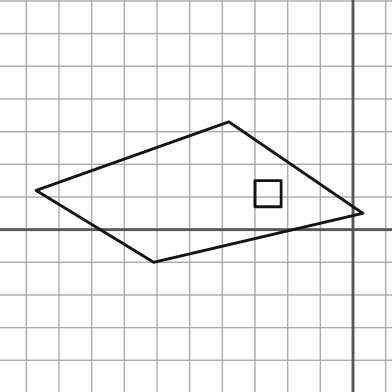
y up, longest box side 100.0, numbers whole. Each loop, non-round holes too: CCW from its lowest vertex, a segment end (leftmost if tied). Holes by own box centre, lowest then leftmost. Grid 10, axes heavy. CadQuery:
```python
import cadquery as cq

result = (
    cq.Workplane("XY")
    .moveTo(-61.0, -10.0)
    .lineTo(3.0, 5.0)
    .lineTo(-38.0, 33.0)
    .lineTo(-97.0, 12.0)
    .close()
    .moveTo(-30.0, 7.0)
    .lineTo(-22.0, 7.0)
    .lineTo(-22.0, 15.0)
    .lineTo(-30.0, 15.0)
    .close()
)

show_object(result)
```